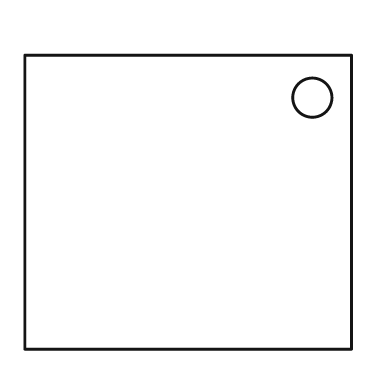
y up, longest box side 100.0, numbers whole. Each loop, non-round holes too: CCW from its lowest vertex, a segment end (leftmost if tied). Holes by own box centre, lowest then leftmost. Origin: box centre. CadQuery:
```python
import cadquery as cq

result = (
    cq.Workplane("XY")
    .moveTo(-50.0, -45.0)
    .lineTo(50.0, -45.0)
    .lineTo(50.0, 45.0)
    .lineTo(-50.0, 45.0)
    .close()
    .moveTo(38.0, 32.0)
    .circle(6.0)
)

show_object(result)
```